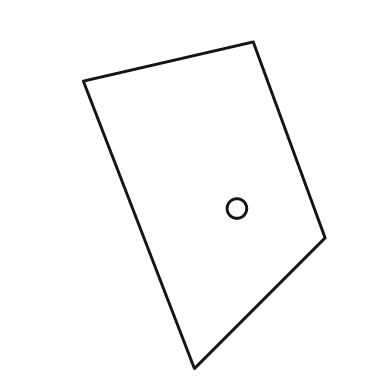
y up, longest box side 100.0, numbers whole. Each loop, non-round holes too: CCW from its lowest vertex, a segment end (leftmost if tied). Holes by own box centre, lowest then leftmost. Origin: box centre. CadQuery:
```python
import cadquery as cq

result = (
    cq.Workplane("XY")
    .moveTo(-3.0, -50.0)
    .lineTo(37.0, -10.0)
    .lineTo(15.0, 50.0)
    .lineTo(-37.0, 38.0)
    .close()
    .moveTo(10.0, -1.0)
    .circle(3.0)
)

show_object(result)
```